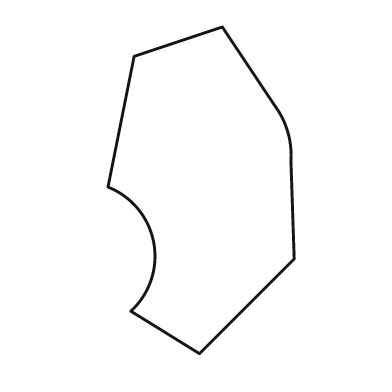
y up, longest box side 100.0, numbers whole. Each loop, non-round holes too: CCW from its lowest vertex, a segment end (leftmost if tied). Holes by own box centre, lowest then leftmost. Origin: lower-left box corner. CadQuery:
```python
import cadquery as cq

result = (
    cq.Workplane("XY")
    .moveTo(28.0, 0.0)
    .lineTo(57.0, 29.0)
    .lineTo(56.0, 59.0)
    .threePointArc((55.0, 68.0), (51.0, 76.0))
    .lineTo(35.0, 100.0)
    .lineTo(8.0, 91.0)
    .lineTo(0.0, 51.0)
    .threePointArc((14.0, 34.0), (7.0, 13.0))
    .close()
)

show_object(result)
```